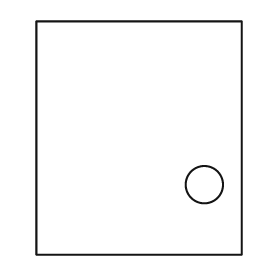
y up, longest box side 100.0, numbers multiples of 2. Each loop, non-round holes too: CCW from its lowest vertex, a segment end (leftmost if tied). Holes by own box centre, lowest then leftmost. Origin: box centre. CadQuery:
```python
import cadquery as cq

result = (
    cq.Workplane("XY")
    .moveTo(-44.0, -50.0)
    .lineTo(44.0, -50.0)
    .lineTo(44.0, 50.0)
    .lineTo(-44.0, 50.0)
    .close()
    .moveTo(28.0, -20.0)
    .circle(8.0)
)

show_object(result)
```